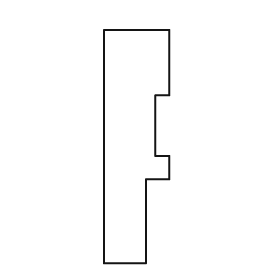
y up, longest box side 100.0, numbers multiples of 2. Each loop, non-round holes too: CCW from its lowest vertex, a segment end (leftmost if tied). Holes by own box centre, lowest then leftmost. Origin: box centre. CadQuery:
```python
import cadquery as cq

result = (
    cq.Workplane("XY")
    .moveTo(-14.0, -50.0)
    .lineTo(4.0, -50.0)
    .lineTo(4.0, -14.0)
    .lineTo(14.0, -14.0)
    .lineTo(14.0, -4.0)
    .lineTo(8.0, -4.0)
    .lineTo(8.0, 22.0)
    .lineTo(14.0, 22.0)
    .lineTo(14.0, 50.0)
    .lineTo(-14.0, 50.0)
    .close()
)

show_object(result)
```